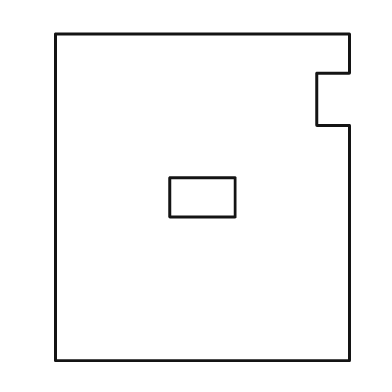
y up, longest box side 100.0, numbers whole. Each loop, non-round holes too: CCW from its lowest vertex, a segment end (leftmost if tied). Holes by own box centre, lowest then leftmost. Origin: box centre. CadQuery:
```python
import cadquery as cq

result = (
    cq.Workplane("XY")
    .moveTo(-45.0, -50.0)
    .lineTo(45.0, -50.0)
    .lineTo(45.0, 22.0)
    .lineTo(35.0, 22.0)
    .lineTo(35.0, 38.0)
    .lineTo(45.0, 38.0)
    .lineTo(45.0, 50.0)
    .lineTo(-45.0, 50.0)
    .close()
    .moveTo(-10.0, -6.0)
    .lineTo(10.0, -6.0)
    .lineTo(10.0, 6.0)
    .lineTo(-10.0, 6.0)
    .close()
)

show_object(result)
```